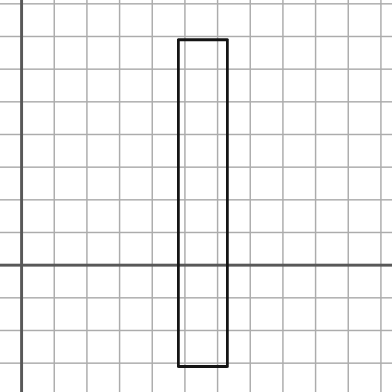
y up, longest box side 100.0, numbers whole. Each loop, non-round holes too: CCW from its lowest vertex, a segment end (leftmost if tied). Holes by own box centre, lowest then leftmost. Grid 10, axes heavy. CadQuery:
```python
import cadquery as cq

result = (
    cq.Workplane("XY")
    .moveTo(48.0, -31.0)
    .lineTo(63.0, -31.0)
    .lineTo(63.0, 69.0)
    .lineTo(48.0, 69.0)
    .close()
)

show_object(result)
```